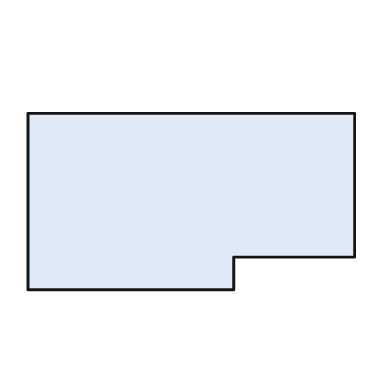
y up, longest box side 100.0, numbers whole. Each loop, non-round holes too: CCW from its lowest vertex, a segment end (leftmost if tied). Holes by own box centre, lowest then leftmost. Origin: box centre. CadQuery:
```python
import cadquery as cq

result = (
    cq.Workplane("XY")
    .moveTo(-50.0, -27.0)
    .lineTo(13.0, -27.0)
    .lineTo(13.0, -17.0)
    .lineTo(50.0, -17.0)
    .lineTo(50.0, 27.0)
    .lineTo(-50.0, 27.0)
    .close()
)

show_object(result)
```